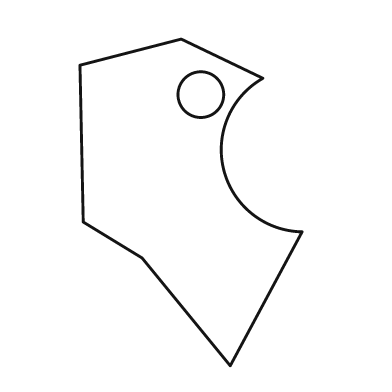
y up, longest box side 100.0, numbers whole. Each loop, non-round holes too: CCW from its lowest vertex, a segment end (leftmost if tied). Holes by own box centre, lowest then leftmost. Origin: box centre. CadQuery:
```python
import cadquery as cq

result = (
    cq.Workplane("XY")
    .moveTo(12.0, -50.0)
    .lineTo(34.0, -9.0)
    .threePointArc((10.0, 10.0), (22.0, 38.0))
    .lineTo(-3.0, 50.0)
    .lineTo(-34.0, 42.0)
    .lineTo(-33.0, -6.0)
    .lineTo(-15.0, -17.0)
    .close()
    .moveTo(3.0, 33.0)
    .circle(7.0)
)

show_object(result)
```